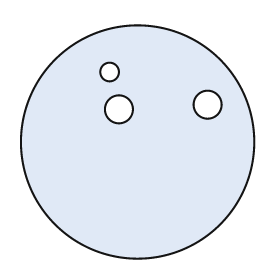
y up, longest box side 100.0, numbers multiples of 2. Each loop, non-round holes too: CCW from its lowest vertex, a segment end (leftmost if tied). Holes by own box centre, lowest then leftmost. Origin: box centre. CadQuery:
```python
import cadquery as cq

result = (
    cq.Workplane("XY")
    .moveTo(0.0, 0.0)
    .circle(50.0)
    .moveTo(-8.0, 14.0)
    .circle(6.0)
    .moveTo(30.0, 16.0)
    .circle(6.0)
    .moveTo(-12.0, 30.0)
    .circle(4.0)
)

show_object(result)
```